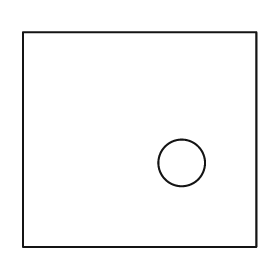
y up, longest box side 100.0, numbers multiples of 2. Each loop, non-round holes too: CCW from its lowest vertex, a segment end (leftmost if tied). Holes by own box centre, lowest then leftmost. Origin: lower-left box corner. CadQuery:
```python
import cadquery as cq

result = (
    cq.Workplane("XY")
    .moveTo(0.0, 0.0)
    .lineTo(100.0, 0.0)
    .lineTo(100.0, 92.0)
    .lineTo(0.0, 92.0)
    .close()
    .moveTo(68.0, 36.0)
    .circle(10.0)
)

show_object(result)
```